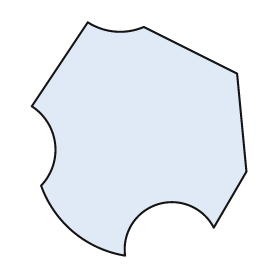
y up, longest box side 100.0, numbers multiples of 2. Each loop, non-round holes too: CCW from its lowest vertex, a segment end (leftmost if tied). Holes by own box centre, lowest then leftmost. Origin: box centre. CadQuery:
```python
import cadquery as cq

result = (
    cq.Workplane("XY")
    .moveTo(-6.0, -50.0)
    .threePointArc((8.0, -28.0), (32.0, -38.0))
    .lineTo(46.0, -14.0)
    .lineTo(42.0, 28.0)
    .lineTo(2.0, 48.0)
    .threePointArc((-10.0, 46.0), (-22.0, 50.0))
    .lineTo(-46.0, 14.0)
    .threePointArc((-36.0, -2.0), (-42.0, -20.0))
    .threePointArc((-28.0, -40.0), (-6.0, -50.0))
    .close()
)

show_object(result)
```